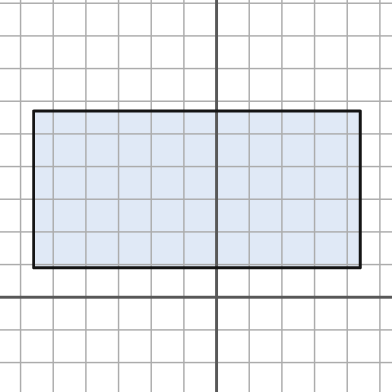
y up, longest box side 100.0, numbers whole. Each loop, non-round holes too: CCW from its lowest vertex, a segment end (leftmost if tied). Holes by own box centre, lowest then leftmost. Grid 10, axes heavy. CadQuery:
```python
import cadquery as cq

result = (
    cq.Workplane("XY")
    .moveTo(-56.0, 9.0)
    .lineTo(44.0, 9.0)
    .lineTo(44.0, 57.0)
    .lineTo(-56.0, 57.0)
    .close()
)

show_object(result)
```